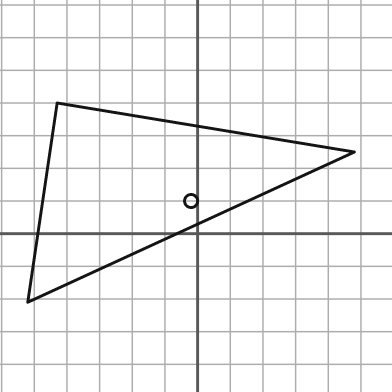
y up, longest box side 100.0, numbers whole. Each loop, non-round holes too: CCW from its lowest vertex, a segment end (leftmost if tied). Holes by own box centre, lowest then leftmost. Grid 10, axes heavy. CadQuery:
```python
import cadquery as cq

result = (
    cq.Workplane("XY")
    .moveTo(-52.0, -21.0)
    .lineTo(48.0, 25.0)
    .lineTo(-43.0, 40.0)
    .close()
    .moveTo(-2.0, 10.0)
    .circle(2.0)
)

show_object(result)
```